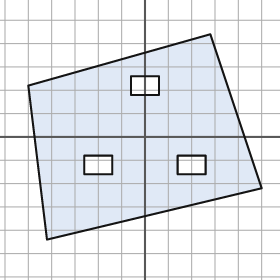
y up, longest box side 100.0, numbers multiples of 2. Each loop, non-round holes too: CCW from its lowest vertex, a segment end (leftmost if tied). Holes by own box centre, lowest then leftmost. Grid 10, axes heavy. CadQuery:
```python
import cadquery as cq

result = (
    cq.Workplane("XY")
    .moveTo(-42.0, -44.0)
    .lineTo(50.0, -22.0)
    .lineTo(28.0, 44.0)
    .lineTo(-50.0, 22.0)
    .close()
    .moveTo(-26.0, -16.0)
    .lineTo(-14.0, -16.0)
    .lineTo(-14.0, -8.0)
    .lineTo(-26.0, -8.0)
    .close()
    .moveTo(14.0, -16.0)
    .lineTo(26.0, -16.0)
    .lineTo(26.0, -8.0)
    .lineTo(14.0, -8.0)
    .close()
    .moveTo(-6.0, 18.0)
    .lineTo(6.0, 18.0)
    .lineTo(6.0, 26.0)
    .lineTo(-6.0, 26.0)
    .close()
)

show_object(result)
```